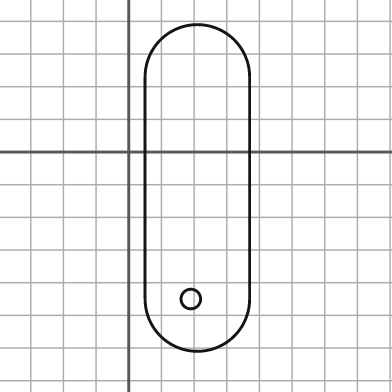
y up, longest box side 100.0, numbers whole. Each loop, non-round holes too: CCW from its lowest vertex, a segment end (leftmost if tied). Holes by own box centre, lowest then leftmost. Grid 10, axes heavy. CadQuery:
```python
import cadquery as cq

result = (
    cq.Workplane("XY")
    .moveTo(5.0, -45.0)
    .threePointArc((21.0, -61.0), (37.0, -45.0))
    .lineTo(37.0, 23.0)
    .threePointArc((21.0, 39.0), (5.0, 23.0))
    .close()
    .moveTo(19.0, -45.0)
    .circle(3.0)
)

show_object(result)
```